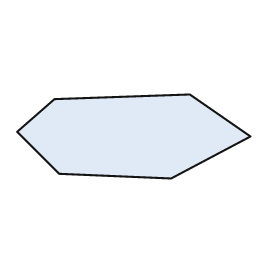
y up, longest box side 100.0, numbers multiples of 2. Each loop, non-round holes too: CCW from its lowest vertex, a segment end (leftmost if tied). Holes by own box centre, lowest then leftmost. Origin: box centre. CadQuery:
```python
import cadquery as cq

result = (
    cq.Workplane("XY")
    .moveTo(16.0, -18.0)
    .lineTo(50.0, 0.0)
    .lineTo(24.0, 18.0)
    .lineTo(-34.0, 16.0)
    .lineTo(-50.0, 2.0)
    .lineTo(-32.0, -16.0)
    .close()
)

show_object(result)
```